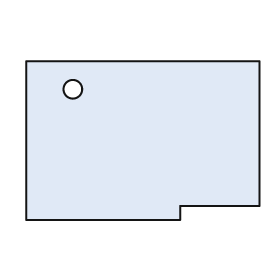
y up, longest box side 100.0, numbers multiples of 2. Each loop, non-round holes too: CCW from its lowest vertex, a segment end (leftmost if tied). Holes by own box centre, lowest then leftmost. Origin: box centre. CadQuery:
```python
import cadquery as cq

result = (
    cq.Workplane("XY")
    .moveTo(-50.0, -34.0)
    .lineTo(16.0, -34.0)
    .lineTo(16.0, -28.0)
    .lineTo(50.0, -28.0)
    .lineTo(50.0, 34.0)
    .lineTo(-50.0, 34.0)
    .close()
    .moveTo(-30.0, 22.0)
    .circle(4.0)
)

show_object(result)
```